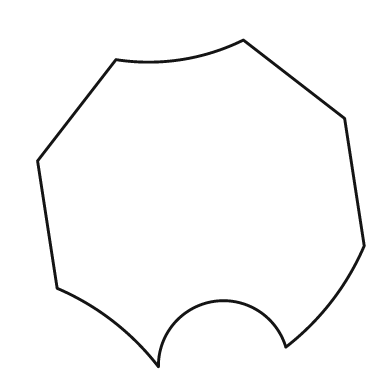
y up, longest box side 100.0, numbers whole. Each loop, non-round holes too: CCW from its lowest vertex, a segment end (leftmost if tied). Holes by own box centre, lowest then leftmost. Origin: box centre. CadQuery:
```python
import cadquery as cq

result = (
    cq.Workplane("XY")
    .moveTo(-13.0, -50.0)
    .threePointArc((4.0, -30.0), (26.0, -44.0))
    .threePointArc((40.0, -30.0), (50.0, -13.0))
    .lineTo(44.0, 26.0)
    .lineTo(13.0, 50.0)
    .threePointArc((-6.0, 44.0), (-26.0, 44.0))
    .lineTo(-50.0, 13.0)
    .lineTo(-44.0, -26.0)
    .threePointArc((-27.0, -36.0), (-13.0, -50.0))
    .close()
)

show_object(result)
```